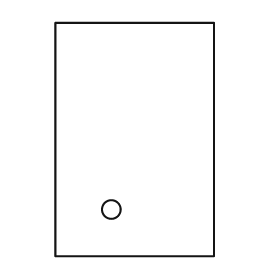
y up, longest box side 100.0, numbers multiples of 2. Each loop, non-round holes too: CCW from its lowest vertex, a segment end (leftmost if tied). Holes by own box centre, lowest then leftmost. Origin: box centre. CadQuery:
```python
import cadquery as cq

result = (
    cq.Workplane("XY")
    .moveTo(-34.0, -50.0)
    .lineTo(34.0, -50.0)
    .lineTo(34.0, 50.0)
    .lineTo(-34.0, 50.0)
    .close()
    .moveTo(-10.0, -30.0)
    .circle(4.0)
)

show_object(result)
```